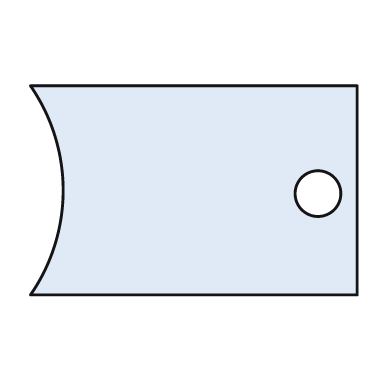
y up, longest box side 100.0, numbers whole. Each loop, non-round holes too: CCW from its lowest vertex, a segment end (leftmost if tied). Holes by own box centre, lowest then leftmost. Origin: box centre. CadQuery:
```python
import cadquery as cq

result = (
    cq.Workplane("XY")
    .moveTo(-50.0, -32.0)
    .lineTo(50.0, -32.0)
    .lineTo(50.0, 32.0)
    .lineTo(-50.0, 32.0)
    .threePointArc((-40.0, 0.0), (-50.0, -32.0))
    .close()
    .moveTo(38.0, -1.0)
    .circle(7.0)
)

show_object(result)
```